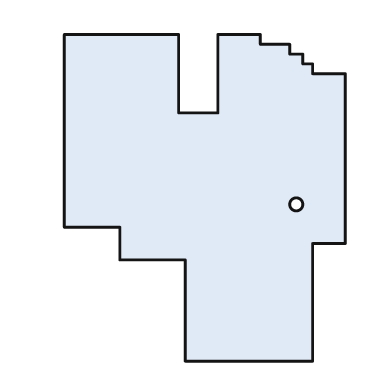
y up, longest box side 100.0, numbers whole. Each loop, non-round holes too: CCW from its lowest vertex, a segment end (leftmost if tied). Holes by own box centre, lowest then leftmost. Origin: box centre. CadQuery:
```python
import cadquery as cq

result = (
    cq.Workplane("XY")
    .moveTo(-6.0, -50.0)
    .lineTo(33.0, -50.0)
    .lineTo(33.0, -14.0)
    .lineTo(43.0, -14.0)
    .lineTo(43.0, 38.0)
    .lineTo(33.0, 38.0)
    .lineTo(33.0, 41.0)
    .lineTo(30.0, 41.0)
    .lineTo(30.0, 44.0)
    .lineTo(26.0, 44.0)
    .lineTo(26.0, 47.0)
    .lineTo(17.0, 47.0)
    .lineTo(17.0, 50.0)
    .lineTo(4.0, 50.0)
    .lineTo(4.0, 26.0)
    .lineTo(-8.0, 26.0)
    .lineTo(-8.0, 50.0)
    .lineTo(-43.0, 50.0)
    .lineTo(-43.0, -9.0)
    .lineTo(-26.0, -9.0)
    .lineTo(-26.0, -19.0)
    .lineTo(-6.0, -19.0)
    .close()
    .moveTo(28.0, -2.0)
    .circle(2.0)
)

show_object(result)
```